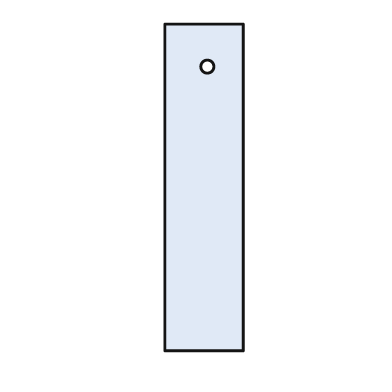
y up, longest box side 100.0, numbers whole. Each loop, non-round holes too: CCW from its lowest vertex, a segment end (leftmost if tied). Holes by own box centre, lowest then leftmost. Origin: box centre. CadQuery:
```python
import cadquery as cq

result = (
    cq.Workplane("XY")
    .moveTo(-12.0, -50.0)
    .lineTo(12.0, -50.0)
    .lineTo(12.0, 50.0)
    .lineTo(-12.0, 50.0)
    .close()
    .moveTo(1.0, 37.0)
    .circle(2.0)
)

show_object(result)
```